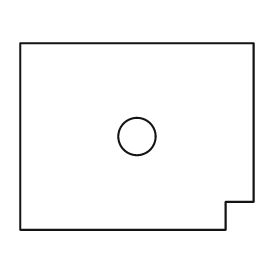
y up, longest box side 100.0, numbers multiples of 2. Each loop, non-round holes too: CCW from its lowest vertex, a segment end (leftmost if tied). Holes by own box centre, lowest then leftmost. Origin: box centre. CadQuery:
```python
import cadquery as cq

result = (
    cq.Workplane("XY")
    .moveTo(-50.0, -40.0)
    .lineTo(38.0, -40.0)
    .lineTo(38.0, -28.0)
    .lineTo(50.0, -28.0)
    .lineTo(50.0, 40.0)
    .lineTo(-50.0, 40.0)
    .close()
    .moveTo(0.0, 0.0)
    .circle(8.0)
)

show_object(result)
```